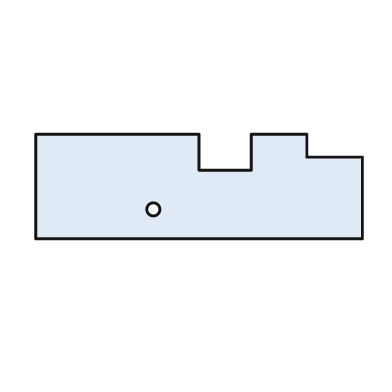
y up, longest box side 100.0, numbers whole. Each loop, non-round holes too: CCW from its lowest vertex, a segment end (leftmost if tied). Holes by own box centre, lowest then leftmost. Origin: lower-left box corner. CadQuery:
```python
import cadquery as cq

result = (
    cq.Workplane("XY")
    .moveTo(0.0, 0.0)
    .lineTo(100.0, 0.0)
    .lineTo(100.0, 25.0)
    .lineTo(83.0, 25.0)
    .lineTo(83.0, 32.0)
    .lineTo(66.0, 32.0)
    .lineTo(66.0, 21.0)
    .lineTo(50.0, 21.0)
    .lineTo(50.0, 32.0)
    .lineTo(0.0, 32.0)
    .close()
    .moveTo(36.0, 9.0)
    .circle(2.0)
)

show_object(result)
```